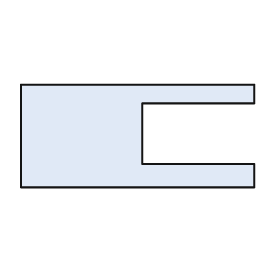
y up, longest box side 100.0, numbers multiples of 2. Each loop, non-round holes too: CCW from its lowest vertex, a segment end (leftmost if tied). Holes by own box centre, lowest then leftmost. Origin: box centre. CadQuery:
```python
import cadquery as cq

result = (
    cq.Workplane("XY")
    .moveTo(-50.0, -22.0)
    .lineTo(50.0, -22.0)
    .lineTo(50.0, -12.0)
    .lineTo(2.0, -12.0)
    .lineTo(2.0, 14.0)
    .lineTo(50.0, 14.0)
    .lineTo(50.0, 22.0)
    .lineTo(-50.0, 22.0)
    .close()
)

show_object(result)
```